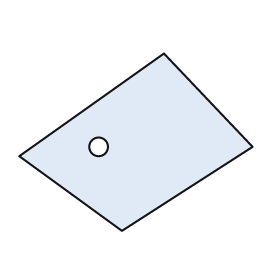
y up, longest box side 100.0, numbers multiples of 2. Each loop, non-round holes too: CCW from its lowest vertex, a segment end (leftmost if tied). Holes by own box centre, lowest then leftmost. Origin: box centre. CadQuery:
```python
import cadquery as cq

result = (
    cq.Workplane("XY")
    .moveTo(-6.0, -38.0)
    .lineTo(50.0, -2.0)
    .lineTo(12.0, 38.0)
    .lineTo(-50.0, -6.0)
    .close()
    .moveTo(-16.0, -2.0)
    .circle(4.0)
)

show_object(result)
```